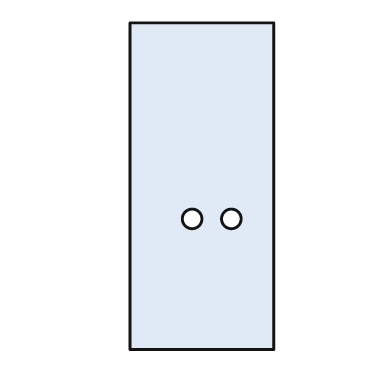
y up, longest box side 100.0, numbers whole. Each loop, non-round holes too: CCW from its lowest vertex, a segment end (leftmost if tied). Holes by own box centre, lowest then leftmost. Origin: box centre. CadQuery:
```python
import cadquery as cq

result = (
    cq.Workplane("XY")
    .moveTo(-22.0, -50.0)
    .lineTo(22.0, -50.0)
    .lineTo(22.0, 50.0)
    .lineTo(-22.0, 50.0)
    .close()
    .moveTo(-3.0, -10.0)
    .circle(3.0)
    .moveTo(9.0, -10.0)
    .circle(3.0)
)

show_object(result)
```